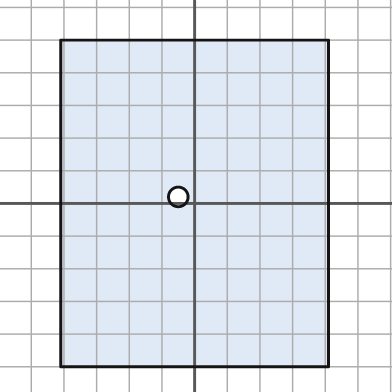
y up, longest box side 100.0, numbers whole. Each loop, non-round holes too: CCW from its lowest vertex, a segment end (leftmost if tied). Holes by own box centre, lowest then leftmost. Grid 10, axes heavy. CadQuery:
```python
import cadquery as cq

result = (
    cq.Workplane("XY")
    .moveTo(-41.0, -50.0)
    .lineTo(41.0, -50.0)
    .lineTo(41.0, 50.0)
    .lineTo(-41.0, 50.0)
    .close()
    .moveTo(-5.0, 2.0)
    .circle(3.0)
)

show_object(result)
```